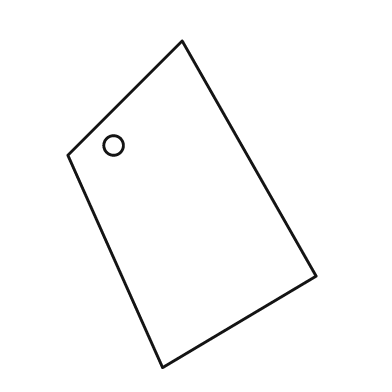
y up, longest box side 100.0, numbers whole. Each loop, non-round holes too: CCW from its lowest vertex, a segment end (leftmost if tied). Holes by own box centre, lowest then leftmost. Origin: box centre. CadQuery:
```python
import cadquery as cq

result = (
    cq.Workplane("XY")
    .moveTo(-9.0, -50.0)
    .lineTo(38.0, -22.0)
    .lineTo(-3.0, 50.0)
    .lineTo(-38.0, 15.0)
    .close()
    .moveTo(-24.0, 18.0)
    .circle(3.0)
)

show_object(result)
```